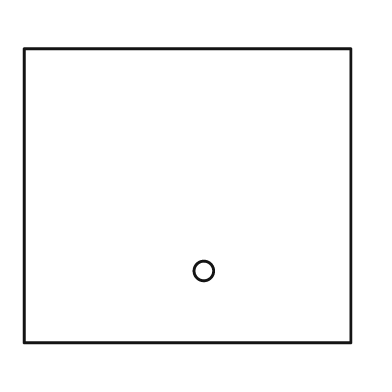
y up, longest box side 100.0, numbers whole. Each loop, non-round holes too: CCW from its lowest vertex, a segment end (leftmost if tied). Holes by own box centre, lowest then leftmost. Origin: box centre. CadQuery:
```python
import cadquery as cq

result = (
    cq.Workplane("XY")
    .moveTo(-50.0, -45.0)
    .lineTo(50.0, -45.0)
    .lineTo(50.0, 45.0)
    .lineTo(-50.0, 45.0)
    .close()
    .moveTo(5.0, -23.0)
    .circle(3.0)
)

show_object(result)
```